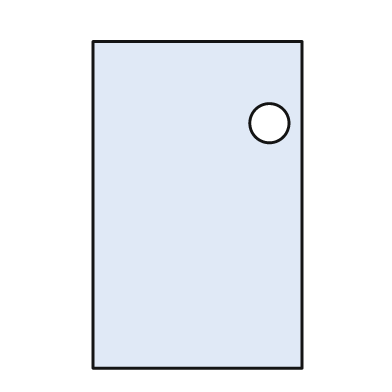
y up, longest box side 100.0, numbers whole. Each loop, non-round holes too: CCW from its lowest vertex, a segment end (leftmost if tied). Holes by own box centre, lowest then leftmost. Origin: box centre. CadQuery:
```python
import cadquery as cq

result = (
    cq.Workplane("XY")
    .moveTo(-32.0, -50.0)
    .lineTo(32.0, -50.0)
    .lineTo(32.0, 50.0)
    .lineTo(-32.0, 50.0)
    .close()
    .moveTo(22.0, 25.0)
    .circle(6.0)
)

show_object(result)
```